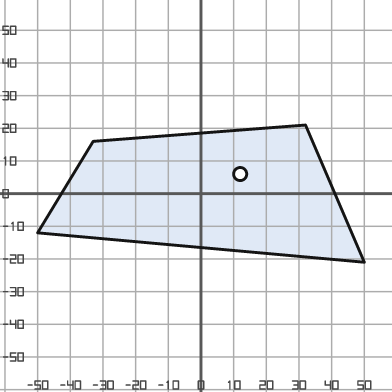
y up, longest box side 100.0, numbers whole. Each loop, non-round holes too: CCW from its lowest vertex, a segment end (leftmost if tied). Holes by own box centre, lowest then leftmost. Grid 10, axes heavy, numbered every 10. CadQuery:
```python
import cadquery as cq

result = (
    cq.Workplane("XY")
    .moveTo(50.0, -21.0)
    .lineTo(32.0, 21.0)
    .lineTo(-33.0, 16.0)
    .lineTo(-50.0, -12.0)
    .close()
    .moveTo(12.0, 6.0)
    .circle(2.0)
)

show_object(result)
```